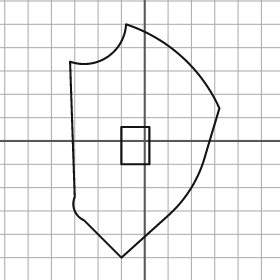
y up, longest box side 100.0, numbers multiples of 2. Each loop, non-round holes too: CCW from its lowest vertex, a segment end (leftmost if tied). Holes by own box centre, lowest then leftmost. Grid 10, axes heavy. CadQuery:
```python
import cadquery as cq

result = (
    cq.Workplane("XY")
    .moveTo(-10.0, -50.0)
    .lineTo(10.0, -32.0)
    .threePointArc((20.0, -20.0), (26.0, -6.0))
    .lineTo(32.0, 14.0)
    .threePointArc((16.0, 36.0), (-8.0, 50.0))
    .threePointArc((-16.0, 36.0), (-32.0, 34.0))
    .lineTo(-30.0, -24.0)
    .threePointArc((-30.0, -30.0), (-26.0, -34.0))
    .close()
    .moveTo(-10.0, -10.0)
    .lineTo(2.0, -10.0)
    .lineTo(2.0, 6.0)
    .lineTo(-10.0, 6.0)
    .close()
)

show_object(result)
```